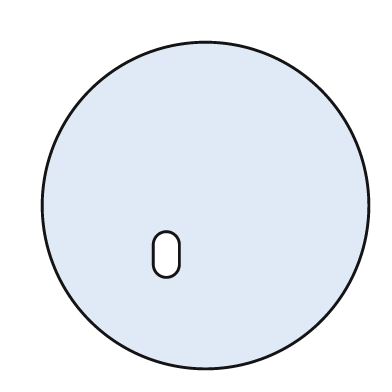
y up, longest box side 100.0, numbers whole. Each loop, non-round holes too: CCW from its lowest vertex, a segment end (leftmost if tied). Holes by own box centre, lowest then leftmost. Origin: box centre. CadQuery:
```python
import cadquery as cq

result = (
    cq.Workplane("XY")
    .moveTo(0.0, 0.0)
    .circle(50.0)
    .moveTo(-16.0, -18.0)
    .threePointArc((-12.0, -22.0), (-8.0, -18.0))
    .lineTo(-8.0, -12.0)
    .threePointArc((-12.0, -8.0), (-16.0, -12.0))
    .close()
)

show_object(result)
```